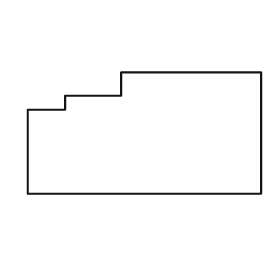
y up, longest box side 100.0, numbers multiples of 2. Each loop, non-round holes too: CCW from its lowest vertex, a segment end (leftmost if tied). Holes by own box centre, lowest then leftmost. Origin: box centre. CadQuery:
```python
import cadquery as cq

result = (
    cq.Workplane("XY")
    .moveTo(-50.0, -26.0)
    .lineTo(50.0, -26.0)
    .lineTo(50.0, 26.0)
    .lineTo(-10.0, 26.0)
    .lineTo(-10.0, 16.0)
    .lineTo(-34.0, 16.0)
    .lineTo(-34.0, 10.0)
    .lineTo(-50.0, 10.0)
    .close()
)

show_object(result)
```